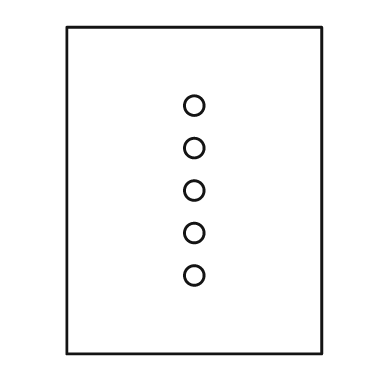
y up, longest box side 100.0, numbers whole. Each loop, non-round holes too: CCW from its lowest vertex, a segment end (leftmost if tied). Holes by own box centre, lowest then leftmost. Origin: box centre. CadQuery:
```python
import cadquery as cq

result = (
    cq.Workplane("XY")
    .moveTo(-39.0, -50.0)
    .lineTo(39.0, -50.0)
    .lineTo(39.0, 50.0)
    .lineTo(-39.0, 50.0)
    .close()
    .moveTo(0.0, -26.0)
    .circle(3.0)
    .moveTo(0.0, -13.0)
    .circle(3.0)
    .moveTo(0.0, 0.0)
    .circle(3.0)
    .moveTo(0.0, 13.0)
    .circle(3.0)
    .moveTo(0.0, 26.0)
    .circle(3.0)
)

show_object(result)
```